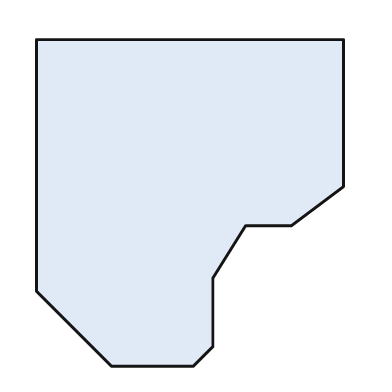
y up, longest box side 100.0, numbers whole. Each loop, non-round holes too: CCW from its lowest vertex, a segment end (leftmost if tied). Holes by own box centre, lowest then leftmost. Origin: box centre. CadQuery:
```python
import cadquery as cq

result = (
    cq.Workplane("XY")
    .moveTo(-24.0, -50.0)
    .lineTo(1.0, -50.0)
    .lineTo(7.0, -44.0)
    .lineTo(7.0, -23.0)
    .lineTo(17.0, -7.0)
    .lineTo(31.0, -7.0)
    .lineTo(47.0, 5.0)
    .lineTo(47.0, 50.0)
    .lineTo(-47.0, 50.0)
    .lineTo(-47.0, -27.0)
    .close()
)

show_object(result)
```